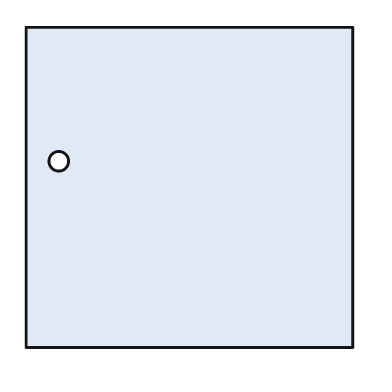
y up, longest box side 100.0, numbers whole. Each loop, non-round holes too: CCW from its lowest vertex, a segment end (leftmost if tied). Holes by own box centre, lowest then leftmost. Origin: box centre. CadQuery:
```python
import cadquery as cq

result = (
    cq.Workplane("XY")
    .moveTo(-50.0, -49.0)
    .lineTo(50.0, -49.0)
    .lineTo(50.0, 49.0)
    .lineTo(-50.0, 49.0)
    .close()
    .moveTo(-40.0, 8.0)
    .circle(3.0)
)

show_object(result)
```